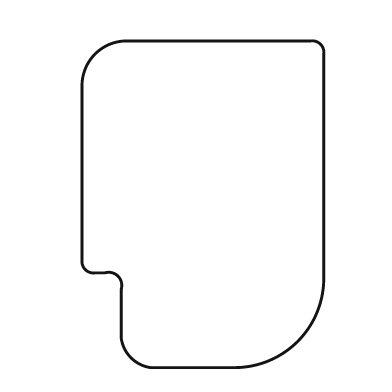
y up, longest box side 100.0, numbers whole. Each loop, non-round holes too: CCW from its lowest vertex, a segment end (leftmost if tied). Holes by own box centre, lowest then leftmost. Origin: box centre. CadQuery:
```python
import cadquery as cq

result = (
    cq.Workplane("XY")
    .moveTo(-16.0, -50.0)
    .lineTo(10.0, -50.0)
    .threePointArc((29.0, -42.0), (37.0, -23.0))
    .lineTo(37.0, 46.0)
    .threePointArc((36.0, 49.0), (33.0, 50.0))
    .lineTo(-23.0, 50.0)
    .threePointArc((-33.0, 46.0), (-37.0, 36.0))
    .lineTo(-37.0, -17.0)
    .threePointArc((-36.0, -20.0), (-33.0, -21.0))
    .lineTo(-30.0, -21.0)
    .threePointArc((-26.0, -22.0), (-25.0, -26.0))
    .lineTo(-25.0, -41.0)
    .threePointArc((-22.0, -47.0), (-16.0, -50.0))
    .close()
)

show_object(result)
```